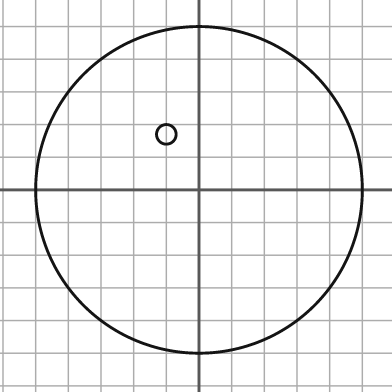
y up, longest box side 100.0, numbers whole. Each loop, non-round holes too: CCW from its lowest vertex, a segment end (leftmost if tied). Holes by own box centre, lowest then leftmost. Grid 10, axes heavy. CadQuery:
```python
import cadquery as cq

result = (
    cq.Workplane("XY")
    .moveTo(0.0, 0.0)
    .circle(50.0)
    .moveTo(-10.0, 17.0)
    .circle(3.0)
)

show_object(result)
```